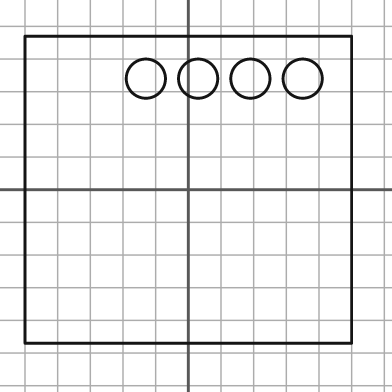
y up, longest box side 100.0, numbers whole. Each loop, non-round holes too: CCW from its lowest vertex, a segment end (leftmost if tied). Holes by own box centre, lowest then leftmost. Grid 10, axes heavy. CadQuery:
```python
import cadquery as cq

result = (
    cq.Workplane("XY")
    .moveTo(-50.0, -47.0)
    .lineTo(50.0, -47.0)
    .lineTo(50.0, 47.0)
    .lineTo(-50.0, 47.0)
    .close()
    .moveTo(-13.0, 34.0)
    .circle(6.0)
    .moveTo(3.0, 34.0)
    .circle(6.0)
    .moveTo(19.0, 34.0)
    .circle(6.0)
    .moveTo(35.0, 34.0)
    .circle(6.0)
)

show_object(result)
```